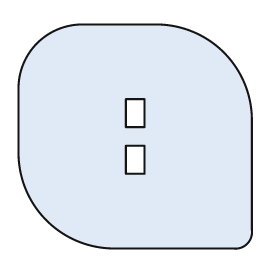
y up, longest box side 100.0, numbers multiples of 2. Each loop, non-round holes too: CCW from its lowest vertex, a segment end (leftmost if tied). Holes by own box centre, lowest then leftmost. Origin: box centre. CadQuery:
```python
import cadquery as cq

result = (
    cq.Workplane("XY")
    .moveTo(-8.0, -48.0)
    .lineTo(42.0, -48.0)
    .threePointArc((48.0, -46.0), (50.0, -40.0))
    .lineTo(50.0, 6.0)
    .threePointArc((38.0, 36.0), (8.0, 48.0))
    .lineTo(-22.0, 48.0)
    .threePointArc((-42.0, 40.0), (-50.0, 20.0))
    .lineTo(-50.0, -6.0)
    .threePointArc((-38.0, -36.0), (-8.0, -48.0))
    .close()
    .moveTo(-4.0, -16.0)
    .lineTo(4.0, -16.0)
    .lineTo(4.0, -4.0)
    .lineTo(-4.0, -4.0)
    .close()
    .moveTo(-4.0, 4.0)
    .lineTo(4.0, 4.0)
    .lineTo(4.0, 16.0)
    .lineTo(-4.0, 16.0)
    .close()
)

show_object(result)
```